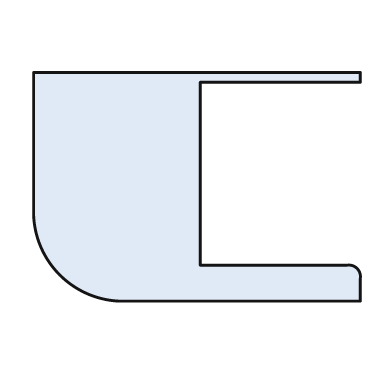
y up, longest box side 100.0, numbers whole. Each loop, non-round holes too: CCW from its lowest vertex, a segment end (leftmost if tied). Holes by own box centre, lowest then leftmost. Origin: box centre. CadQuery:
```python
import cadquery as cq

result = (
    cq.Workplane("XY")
    .moveTo(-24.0, -35.0)
    .lineTo(50.0, -35.0)
    .lineTo(50.0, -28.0)
    .threePointArc((49.0, -25.0), (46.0, -24.0))
    .lineTo(1.0, -24.0)
    .lineTo(1.0, 32.0)
    .lineTo(50.0, 32.0)
    .lineTo(50.0, 35.0)
    .lineTo(-50.0, 35.0)
    .lineTo(-50.0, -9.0)
    .threePointArc((-42.0, -27.0), (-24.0, -35.0))
    .close()
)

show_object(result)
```